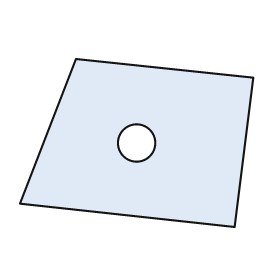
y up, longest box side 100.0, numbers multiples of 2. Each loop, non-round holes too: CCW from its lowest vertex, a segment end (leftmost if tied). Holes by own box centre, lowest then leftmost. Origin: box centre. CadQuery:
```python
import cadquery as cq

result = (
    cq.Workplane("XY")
    .moveTo(42.0, -36.0)
    .lineTo(50.0, 28.0)
    .lineTo(-26.0, 36.0)
    .lineTo(-50.0, -26.0)
    .close()
    .moveTo(0.0, 0.0)
    .circle(8.0)
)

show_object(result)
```